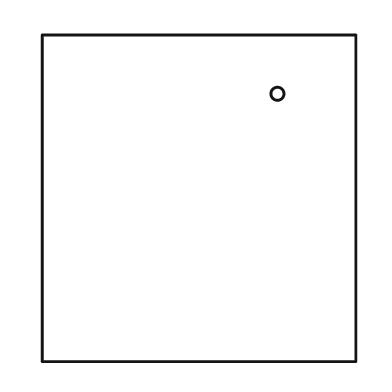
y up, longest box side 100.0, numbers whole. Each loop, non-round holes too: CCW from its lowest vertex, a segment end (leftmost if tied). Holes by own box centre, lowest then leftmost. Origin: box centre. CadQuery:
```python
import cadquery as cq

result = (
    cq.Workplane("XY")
    .moveTo(-48.0, -50.0)
    .lineTo(48.0, -50.0)
    .lineTo(48.0, 50.0)
    .lineTo(-48.0, 50.0)
    .close()
    .moveTo(24.0, 32.0)
    .circle(2.0)
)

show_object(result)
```